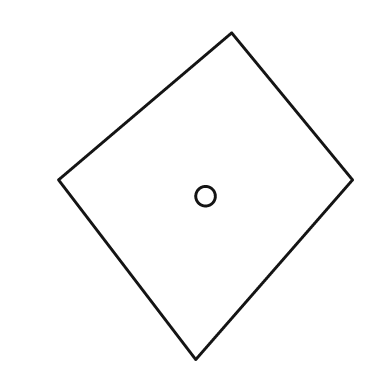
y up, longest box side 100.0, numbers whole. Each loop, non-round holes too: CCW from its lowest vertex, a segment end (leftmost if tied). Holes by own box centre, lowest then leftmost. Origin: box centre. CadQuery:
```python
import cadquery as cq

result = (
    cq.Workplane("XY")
    .moveTo(-3.0, -50.0)
    .lineTo(45.0, 5.0)
    .lineTo(8.0, 50.0)
    .lineTo(-45.0, 5.0)
    .close()
    .moveTo(0.0, 0.0)
    .circle(3.0)
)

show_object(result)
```